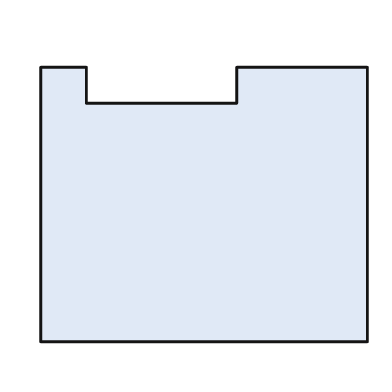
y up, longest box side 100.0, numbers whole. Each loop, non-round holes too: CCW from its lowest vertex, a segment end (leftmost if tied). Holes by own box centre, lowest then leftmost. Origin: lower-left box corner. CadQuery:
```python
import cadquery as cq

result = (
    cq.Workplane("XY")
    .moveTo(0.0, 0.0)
    .lineTo(100.0, 0.0)
    .lineTo(100.0, 84.0)
    .lineTo(60.0, 84.0)
    .lineTo(60.0, 73.0)
    .lineTo(14.0, 73.0)
    .lineTo(14.0, 84.0)
    .lineTo(0.0, 84.0)
    .close()
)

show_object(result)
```